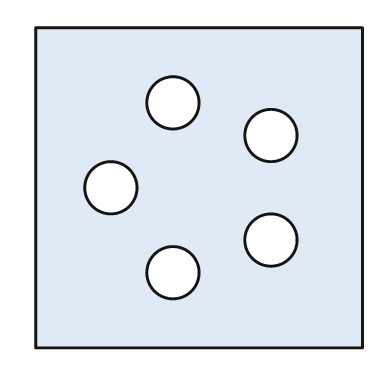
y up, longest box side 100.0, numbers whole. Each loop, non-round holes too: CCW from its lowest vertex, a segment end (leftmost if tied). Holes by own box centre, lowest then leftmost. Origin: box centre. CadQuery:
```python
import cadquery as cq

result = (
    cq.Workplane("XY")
    .moveTo(-50.0, -49.0)
    .lineTo(50.0, -49.0)
    .lineTo(50.0, 49.0)
    .lineTo(-50.0, 49.0)
    .close()
    .moveTo(-8.0, -26.0)
    .circle(8.0)
    .moveTo(22.0, -16.0)
    .circle(8.0)
    .moveTo(-27.0, 0.0)
    .circle(8.0)
    .moveTo(22.0, 16.0)
    .circle(8.0)
    .moveTo(-8.0, 26.0)
    .circle(8.0)
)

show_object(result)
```